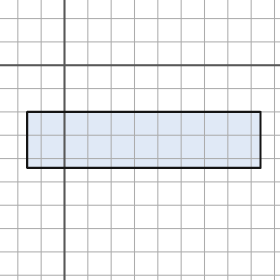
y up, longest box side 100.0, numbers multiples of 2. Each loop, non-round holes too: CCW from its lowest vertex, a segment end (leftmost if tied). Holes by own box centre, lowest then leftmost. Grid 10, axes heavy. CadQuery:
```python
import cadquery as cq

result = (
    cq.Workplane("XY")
    .moveTo(-16.0, -44.0)
    .lineTo(84.0, -44.0)
    .lineTo(84.0, -20.0)
    .lineTo(-16.0, -20.0)
    .close()
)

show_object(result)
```